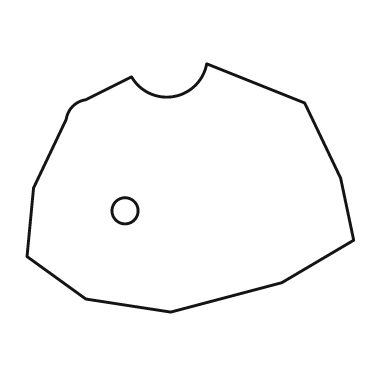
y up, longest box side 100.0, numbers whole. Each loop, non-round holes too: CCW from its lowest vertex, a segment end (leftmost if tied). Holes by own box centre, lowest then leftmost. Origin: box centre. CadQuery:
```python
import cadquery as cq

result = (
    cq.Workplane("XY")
    .moveTo(-6.0, -38.0)
    .lineTo(28.0, -29.0)
    .lineTo(50.0, -16.0)
    .lineTo(46.0, 3.0)
    .lineTo(35.0, 26.0)
    .lineTo(5.0, 38.0)
    .threePointArc((-5.0, 28.0), (-18.0, 34.0))
    .lineTo(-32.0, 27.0)
    .threePointArc((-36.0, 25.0), (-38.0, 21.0))
    .lineTo(-48.0, 0.0)
    .lineTo(-50.0, -21.0)
    .lineTo(-32.0, -34.0)
    .close()
    .moveTo(-20.0, -7.0)
    .circle(4.0)
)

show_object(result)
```